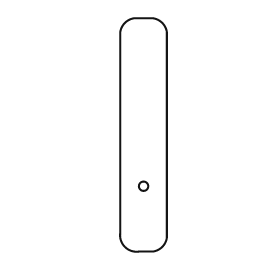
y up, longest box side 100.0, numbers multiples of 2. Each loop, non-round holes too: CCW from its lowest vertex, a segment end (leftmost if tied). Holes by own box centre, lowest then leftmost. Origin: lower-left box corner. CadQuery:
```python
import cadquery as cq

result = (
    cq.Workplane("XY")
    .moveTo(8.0, 0.0)
    .lineTo(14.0, 0.0)
    .threePointArc((18.0, 2.0), (20.0, 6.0))
    .lineTo(20.0, 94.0)
    .threePointArc((18.0, 98.0), (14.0, 100.0))
    .lineTo(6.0, 100.0)
    .threePointArc((2.0, 98.0), (0.0, 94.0))
    .lineTo(0.0, 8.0)
    .threePointArc((2.0, 2.0), (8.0, 0.0))
    .close()
    .moveTo(10.0, 28.0)
    .circle(2.0)
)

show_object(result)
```